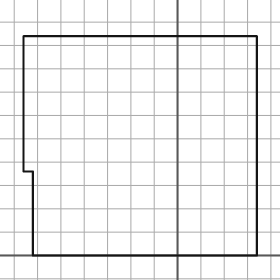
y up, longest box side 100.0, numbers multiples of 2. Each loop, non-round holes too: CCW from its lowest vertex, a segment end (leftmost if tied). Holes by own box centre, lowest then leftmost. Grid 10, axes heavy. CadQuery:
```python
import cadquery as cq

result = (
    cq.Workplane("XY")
    .moveTo(-62.0, 0.0)
    .lineTo(34.0, 0.0)
    .lineTo(34.0, 94.0)
    .lineTo(-66.0, 94.0)
    .lineTo(-66.0, 36.0)
    .lineTo(-62.0, 36.0)
    .close()
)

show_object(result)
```